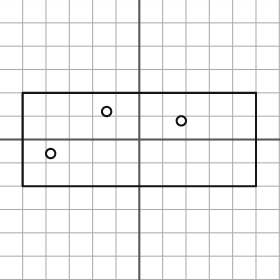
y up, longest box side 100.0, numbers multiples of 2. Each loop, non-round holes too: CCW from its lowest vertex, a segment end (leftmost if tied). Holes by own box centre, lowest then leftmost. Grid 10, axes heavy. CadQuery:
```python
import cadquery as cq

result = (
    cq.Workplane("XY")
    .moveTo(-50.0, -20.0)
    .lineTo(50.0, -20.0)
    .lineTo(50.0, 20.0)
    .lineTo(-50.0, 20.0)
    .close()
    .moveTo(-38.0, -6.0)
    .circle(2.0)
    .moveTo(18.0, 8.0)
    .circle(2.0)
    .moveTo(-14.0, 12.0)
    .circle(2.0)
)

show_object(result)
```